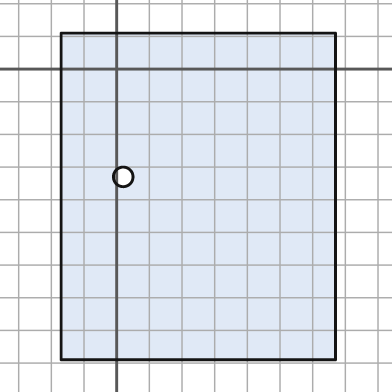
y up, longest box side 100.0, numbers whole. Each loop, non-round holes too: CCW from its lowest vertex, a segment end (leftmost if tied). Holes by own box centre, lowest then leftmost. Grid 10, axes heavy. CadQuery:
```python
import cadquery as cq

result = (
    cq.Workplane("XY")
    .moveTo(-17.0, -89.0)
    .lineTo(67.0, -89.0)
    .lineTo(67.0, 11.0)
    .lineTo(-17.0, 11.0)
    .close()
    .moveTo(2.0, -33.0)
    .circle(3.0)
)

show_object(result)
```